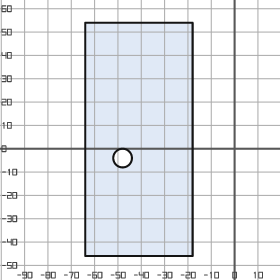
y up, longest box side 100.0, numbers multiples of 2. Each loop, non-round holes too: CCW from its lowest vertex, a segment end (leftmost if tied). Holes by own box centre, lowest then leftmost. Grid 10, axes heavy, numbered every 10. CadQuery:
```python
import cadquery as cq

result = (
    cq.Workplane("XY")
    .moveTo(-64.0, -46.0)
    .lineTo(-18.0, -46.0)
    .lineTo(-18.0, 54.0)
    .lineTo(-64.0, 54.0)
    .close()
    .moveTo(-48.0, -4.0)
    .circle(4.0)
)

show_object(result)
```